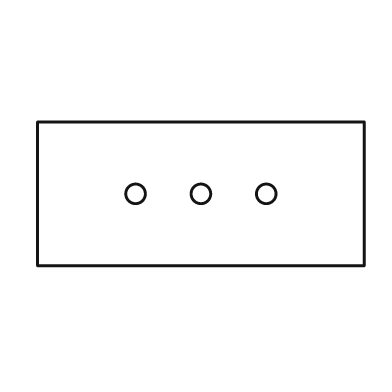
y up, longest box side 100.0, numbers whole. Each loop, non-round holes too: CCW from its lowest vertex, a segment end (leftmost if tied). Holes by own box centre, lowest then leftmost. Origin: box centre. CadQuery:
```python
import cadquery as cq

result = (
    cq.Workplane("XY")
    .moveTo(-50.0, -22.0)
    .lineTo(50.0, -22.0)
    .lineTo(50.0, 22.0)
    .lineTo(-50.0, 22.0)
    .close()
    .moveTo(-20.0, 0.0)
    .circle(3.0)
    .moveTo(0.0, 0.0)
    .circle(3.0)
    .moveTo(20.0, 0.0)
    .circle(3.0)
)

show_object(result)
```